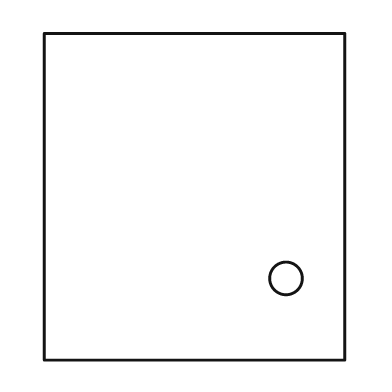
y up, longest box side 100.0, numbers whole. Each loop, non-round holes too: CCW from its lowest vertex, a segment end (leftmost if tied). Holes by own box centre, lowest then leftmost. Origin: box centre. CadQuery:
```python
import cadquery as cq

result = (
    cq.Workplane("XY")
    .moveTo(-46.0, -50.0)
    .lineTo(46.0, -50.0)
    .lineTo(46.0, 50.0)
    .lineTo(-46.0, 50.0)
    .close()
    .moveTo(28.0, -25.0)
    .circle(5.0)
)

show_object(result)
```